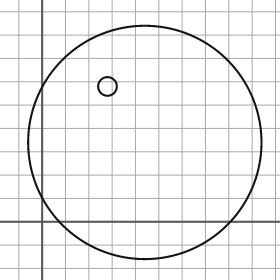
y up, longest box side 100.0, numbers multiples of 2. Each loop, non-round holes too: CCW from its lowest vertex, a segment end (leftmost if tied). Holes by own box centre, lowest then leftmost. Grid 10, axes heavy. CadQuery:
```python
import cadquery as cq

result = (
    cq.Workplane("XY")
    .moveTo(44.0, 34.0)
    .circle(50.0)
    .moveTo(28.0, 58.0)
    .circle(4.0)
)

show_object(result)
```